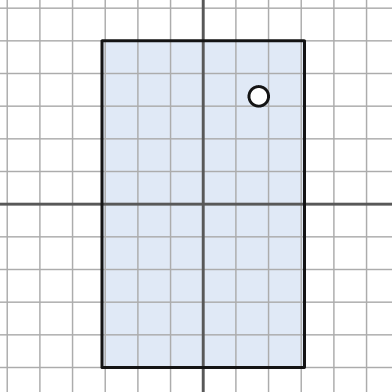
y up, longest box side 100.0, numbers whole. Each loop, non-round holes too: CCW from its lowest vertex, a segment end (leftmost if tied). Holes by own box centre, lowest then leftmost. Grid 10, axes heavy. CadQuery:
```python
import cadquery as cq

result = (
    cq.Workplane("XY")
    .moveTo(-31.0, -50.0)
    .lineTo(31.0, -50.0)
    .lineTo(31.0, 50.0)
    .lineTo(-31.0, 50.0)
    .close()
    .moveTo(17.0, 33.0)
    .circle(3.0)
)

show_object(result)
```